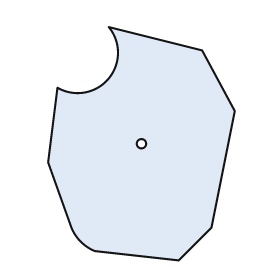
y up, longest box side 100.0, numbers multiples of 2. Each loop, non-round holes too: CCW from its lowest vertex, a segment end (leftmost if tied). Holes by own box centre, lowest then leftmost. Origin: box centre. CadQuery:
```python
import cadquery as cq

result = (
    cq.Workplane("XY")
    .moveTo(16.0, -50.0)
    .lineTo(30.0, -36.0)
    .lineTo(40.0, 14.0)
    .lineTo(26.0, 40.0)
    .lineTo(-14.0, 50.0)
    .threePointArc((-14.0, 28.0), (-36.0, 24.0))
    .lineTo(-40.0, -8.0)
    .lineTo(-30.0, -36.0)
    .threePointArc((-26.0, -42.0), (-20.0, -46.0))
    .close()
    .moveTo(0.0, 0.0)
    .circle(2.0)
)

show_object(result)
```